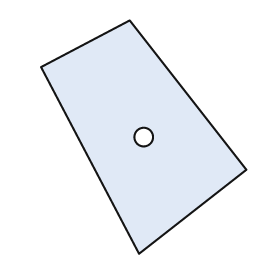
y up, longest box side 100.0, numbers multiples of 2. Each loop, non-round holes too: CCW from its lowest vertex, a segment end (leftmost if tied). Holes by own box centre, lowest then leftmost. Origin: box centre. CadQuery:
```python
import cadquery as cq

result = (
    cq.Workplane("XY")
    .moveTo(-2.0, -50.0)
    .lineTo(44.0, -14.0)
    .lineTo(-6.0, 50.0)
    .lineTo(-44.0, 30.0)
    .close()
    .moveTo(0.0, 0.0)
    .circle(4.0)
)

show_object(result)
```